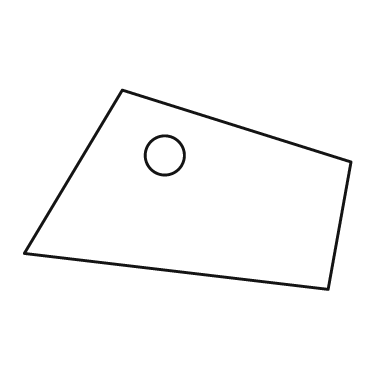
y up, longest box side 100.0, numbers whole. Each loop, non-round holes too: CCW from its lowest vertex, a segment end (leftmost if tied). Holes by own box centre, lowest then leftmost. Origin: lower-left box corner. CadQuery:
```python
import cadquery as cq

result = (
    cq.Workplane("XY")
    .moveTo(93.0, 0.0)
    .lineTo(100.0, 39.0)
    .lineTo(30.0, 61.0)
    .lineTo(0.0, 11.0)
    .close()
    .moveTo(43.0, 41.0)
    .circle(6.0)
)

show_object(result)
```